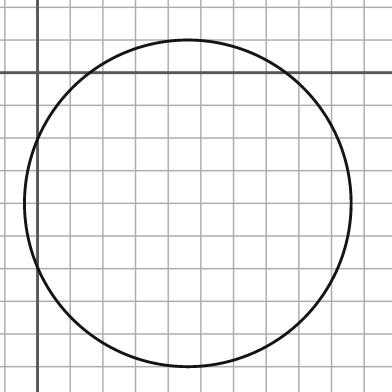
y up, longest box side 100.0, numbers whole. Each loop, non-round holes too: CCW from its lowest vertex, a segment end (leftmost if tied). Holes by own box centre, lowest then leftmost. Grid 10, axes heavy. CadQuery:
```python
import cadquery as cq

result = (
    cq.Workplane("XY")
    .moveTo(46.0, -40.0)
    .circle(50.0)
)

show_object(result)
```